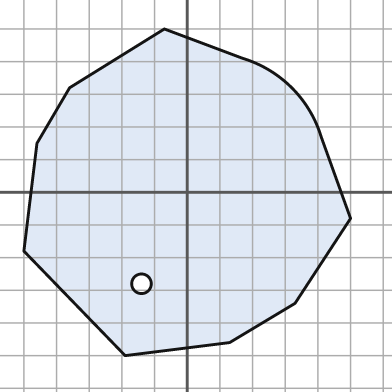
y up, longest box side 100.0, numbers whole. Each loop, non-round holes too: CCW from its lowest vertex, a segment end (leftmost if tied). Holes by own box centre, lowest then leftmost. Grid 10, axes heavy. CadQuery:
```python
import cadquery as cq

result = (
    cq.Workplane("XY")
    .moveTo(-19.0, -50.0)
    .lineTo(13.0, -46.0)
    .lineTo(33.0, -34.0)
    .lineTo(50.0, -8.0)
    .lineTo(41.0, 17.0)
    .threePointArc((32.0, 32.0), (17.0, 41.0))
    .lineTo(-7.0, 50.0)
    .lineTo(-36.0, 32.0)
    .lineTo(-46.0, 15.0)
    .lineTo(-50.0, -18.0)
    .close()
    .moveTo(-14.0, -28.0)
    .circle(3.0)
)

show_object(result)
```